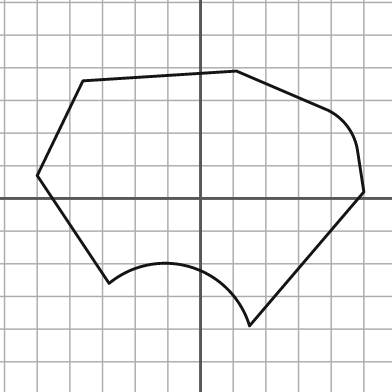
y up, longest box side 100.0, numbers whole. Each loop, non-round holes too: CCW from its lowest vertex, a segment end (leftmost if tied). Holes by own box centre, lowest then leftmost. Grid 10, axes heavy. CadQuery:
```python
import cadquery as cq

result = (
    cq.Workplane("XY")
    .moveTo(15.0, -39.0)
    .lineTo(50.0, 2.0)
    .lineTo(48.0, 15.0)
    .threePointArc((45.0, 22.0), (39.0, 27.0))
    .lineTo(11.0, 39.0)
    .lineTo(-36.0, 36.0)
    .lineTo(-50.0, 7.0)
    .lineTo(-28.0, -26.0)
    .threePointArc((-3.0, -21.0), (15.0, -39.0))
    .close()
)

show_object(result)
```